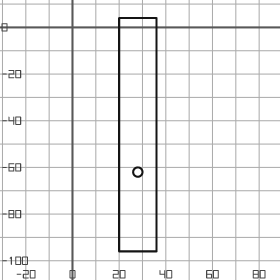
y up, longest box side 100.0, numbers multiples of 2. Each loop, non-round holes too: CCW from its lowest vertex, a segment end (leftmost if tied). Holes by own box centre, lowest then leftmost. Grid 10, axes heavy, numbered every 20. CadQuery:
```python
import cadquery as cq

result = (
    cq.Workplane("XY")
    .moveTo(20.0, -96.0)
    .lineTo(36.0, -96.0)
    .lineTo(36.0, 4.0)
    .lineTo(20.0, 4.0)
    .close()
    .moveTo(28.0, -62.0)
    .circle(2.0)
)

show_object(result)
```